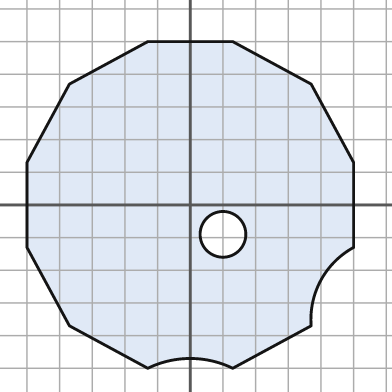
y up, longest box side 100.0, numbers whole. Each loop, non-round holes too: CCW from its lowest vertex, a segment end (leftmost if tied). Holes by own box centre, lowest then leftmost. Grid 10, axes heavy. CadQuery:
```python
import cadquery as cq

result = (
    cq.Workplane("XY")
    .moveTo(-13.0, -50.0)
    .threePointArc((0.0, -47.0), (13.0, -50.0))
    .lineTo(37.0, -37.0)
    .threePointArc((40.0, -23.0), (50.0, -13.0))
    .lineTo(50.0, 13.0)
    .lineTo(37.0, 37.0)
    .lineTo(13.0, 50.0)
    .lineTo(-13.0, 50.0)
    .lineTo(-37.0, 37.0)
    .lineTo(-50.0, 13.0)
    .lineTo(-50.0, -13.0)
    .lineTo(-37.0, -37.0)
    .close()
    .moveTo(10.0, -9.0)
    .circle(7.0)
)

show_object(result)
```